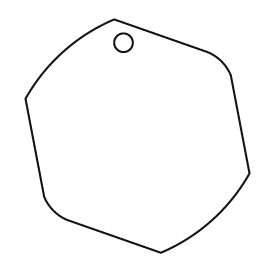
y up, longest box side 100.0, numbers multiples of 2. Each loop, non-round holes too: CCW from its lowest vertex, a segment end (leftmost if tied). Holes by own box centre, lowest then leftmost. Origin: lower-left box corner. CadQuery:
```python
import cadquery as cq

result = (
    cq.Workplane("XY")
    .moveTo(58.0, 0.0)
    .threePointArc((80.0, 14.0), (96.0, 34.0))
    .lineTo(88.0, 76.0)
    .threePointArc((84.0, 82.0), (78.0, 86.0))
    .lineTo(38.0, 100.0)
    .threePointArc((16.0, 86.0), (0.0, 66.0))
    .lineTo(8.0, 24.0)
    .threePointArc((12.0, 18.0), (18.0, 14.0))
    .close()
    .moveTo(42.0, 90.0)
    .circle(4.0)
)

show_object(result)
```